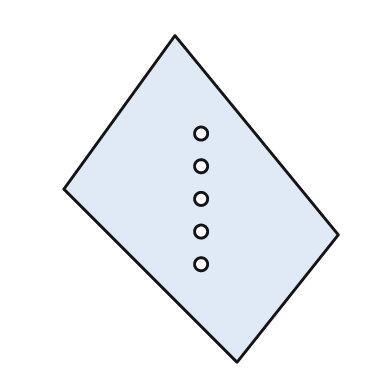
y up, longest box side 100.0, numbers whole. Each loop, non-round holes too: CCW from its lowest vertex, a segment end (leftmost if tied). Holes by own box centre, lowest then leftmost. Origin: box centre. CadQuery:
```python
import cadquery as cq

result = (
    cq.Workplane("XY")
    .moveTo(11.0, -50.0)
    .lineTo(42.0, -11.0)
    .lineTo(-8.0, 50.0)
    .lineTo(-42.0, 3.0)
    .close()
    .moveTo(0.0, -20.0)
    .circle(2.0)
    .moveTo(0.0, -10.0)
    .circle(2.0)
    .moveTo(0.0, 0.0)
    .circle(2.0)
    .moveTo(0.0, 10.0)
    .circle(2.0)
    .moveTo(0.0, 20.0)
    .circle(2.0)
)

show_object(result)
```